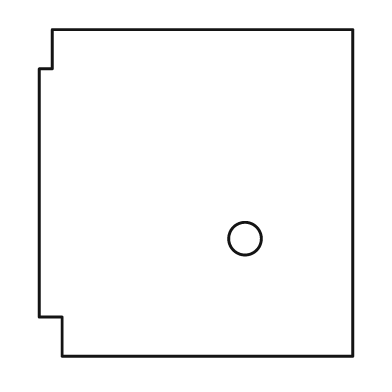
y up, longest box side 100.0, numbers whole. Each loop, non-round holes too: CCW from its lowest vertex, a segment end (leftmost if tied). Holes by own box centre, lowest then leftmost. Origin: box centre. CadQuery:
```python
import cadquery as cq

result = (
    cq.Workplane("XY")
    .moveTo(-41.0, -50.0)
    .lineTo(48.0, -50.0)
    .lineTo(48.0, 50.0)
    .lineTo(-44.0, 50.0)
    .lineTo(-44.0, 38.0)
    .lineTo(-48.0, 38.0)
    .lineTo(-48.0, -38.0)
    .lineTo(-41.0, -38.0)
    .close()
    .moveTo(15.0, -14.0)
    .circle(5.0)
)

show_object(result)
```